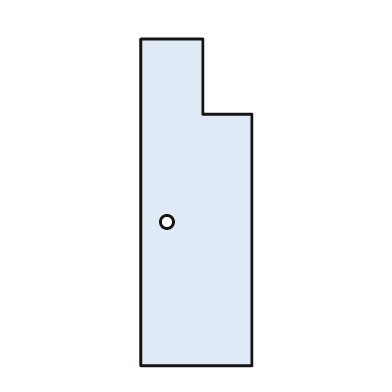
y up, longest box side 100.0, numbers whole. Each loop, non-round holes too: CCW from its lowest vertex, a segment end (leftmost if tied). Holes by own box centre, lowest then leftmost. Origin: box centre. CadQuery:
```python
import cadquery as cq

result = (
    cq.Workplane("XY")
    .moveTo(-17.0, -50.0)
    .lineTo(17.0, -50.0)
    .lineTo(17.0, 27.0)
    .lineTo(2.0, 27.0)
    .lineTo(2.0, 50.0)
    .lineTo(-17.0, 50.0)
    .close()
    .moveTo(-9.0, -6.0)
    .circle(2.0)
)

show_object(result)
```